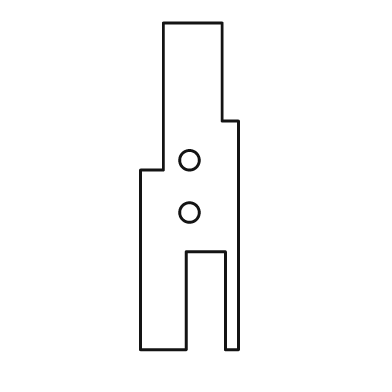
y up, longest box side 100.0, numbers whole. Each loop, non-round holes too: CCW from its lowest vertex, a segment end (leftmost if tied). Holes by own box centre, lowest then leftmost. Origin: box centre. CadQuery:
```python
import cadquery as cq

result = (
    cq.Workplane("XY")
    .moveTo(-15.0, -50.0)
    .lineTo(-1.0, -50.0)
    .lineTo(-1.0, -20.0)
    .lineTo(11.0, -20.0)
    .lineTo(11.0, -50.0)
    .lineTo(15.0, -50.0)
    .lineTo(15.0, 20.0)
    .lineTo(10.0, 20.0)
    .lineTo(10.0, 50.0)
    .lineTo(-8.0, 50.0)
    .lineTo(-8.0, 5.0)
    .lineTo(-15.0, 5.0)
    .close()
    .moveTo(0.0, -8.0)
    .circle(3.0)
    .moveTo(0.0, 8.0)
    .circle(3.0)
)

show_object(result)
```